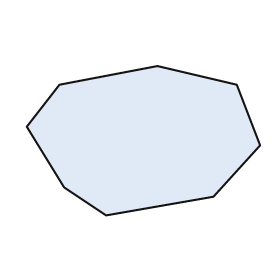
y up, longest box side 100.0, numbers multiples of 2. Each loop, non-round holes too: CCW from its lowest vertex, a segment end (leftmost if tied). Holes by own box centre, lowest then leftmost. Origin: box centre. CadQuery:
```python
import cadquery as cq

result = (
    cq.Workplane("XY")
    .moveTo(-16.0, -32.0)
    .lineTo(30.0, -24.0)
    .lineTo(50.0, -2.0)
    .lineTo(40.0, 24.0)
    .lineTo(6.0, 32.0)
    .lineTo(-36.0, 24.0)
    .lineTo(-50.0, 6.0)
    .lineTo(-34.0, -20.0)
    .close()
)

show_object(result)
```